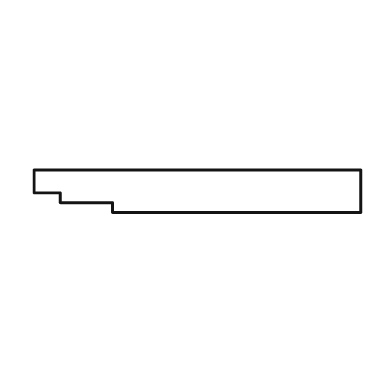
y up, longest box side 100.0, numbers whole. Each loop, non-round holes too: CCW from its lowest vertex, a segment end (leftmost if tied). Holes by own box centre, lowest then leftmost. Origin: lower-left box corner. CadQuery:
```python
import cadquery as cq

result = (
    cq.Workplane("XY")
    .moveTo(24.0, 0.0)
    .lineTo(100.0, 0.0)
    .lineTo(100.0, 13.0)
    .lineTo(0.0, 13.0)
    .lineTo(0.0, 6.0)
    .lineTo(8.0, 6.0)
    .lineTo(8.0, 3.0)
    .lineTo(24.0, 3.0)
    .close()
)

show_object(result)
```